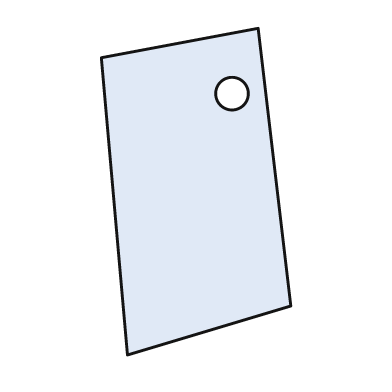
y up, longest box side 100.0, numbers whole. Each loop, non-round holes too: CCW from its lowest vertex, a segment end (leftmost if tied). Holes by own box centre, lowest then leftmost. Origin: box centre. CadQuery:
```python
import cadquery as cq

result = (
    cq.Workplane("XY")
    .moveTo(-21.0, -50.0)
    .lineTo(29.0, -35.0)
    .lineTo(19.0, 50.0)
    .lineTo(-29.0, 41.0)
    .close()
    .moveTo(11.0, 30.0)
    .circle(5.0)
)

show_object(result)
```